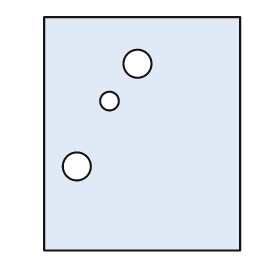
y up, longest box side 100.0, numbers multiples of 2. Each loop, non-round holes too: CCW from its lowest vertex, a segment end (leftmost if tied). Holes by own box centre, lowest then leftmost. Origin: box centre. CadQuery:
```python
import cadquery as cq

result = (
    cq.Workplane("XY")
    .moveTo(-42.0, -50.0)
    .lineTo(42.0, -50.0)
    .lineTo(42.0, 50.0)
    .lineTo(-42.0, 50.0)
    .close()
    .moveTo(-28.0, -14.0)
    .circle(6.0)
    .moveTo(-14.0, 14.0)
    .circle(4.0)
    .moveTo(-2.0, 30.0)
    .circle(6.0)
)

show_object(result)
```